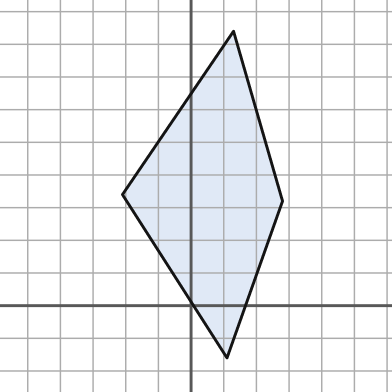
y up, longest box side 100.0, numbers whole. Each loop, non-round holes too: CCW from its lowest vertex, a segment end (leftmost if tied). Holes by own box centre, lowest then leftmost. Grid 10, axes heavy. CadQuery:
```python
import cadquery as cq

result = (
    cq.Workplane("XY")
    .moveTo(11.0, -16.0)
    .lineTo(28.0, 32.0)
    .lineTo(13.0, 84.0)
    .lineTo(-21.0, 34.0)
    .close()
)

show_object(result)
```